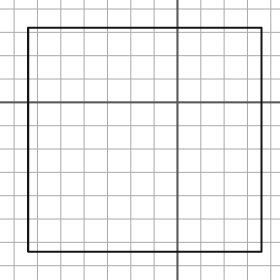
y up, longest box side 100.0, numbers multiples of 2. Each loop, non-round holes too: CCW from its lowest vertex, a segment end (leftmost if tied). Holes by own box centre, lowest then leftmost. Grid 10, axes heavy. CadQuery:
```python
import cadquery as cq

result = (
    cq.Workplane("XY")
    .moveTo(-64.0, -64.0)
    .lineTo(36.0, -64.0)
    .lineTo(36.0, 32.0)
    .lineTo(-64.0, 32.0)
    .close()
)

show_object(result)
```